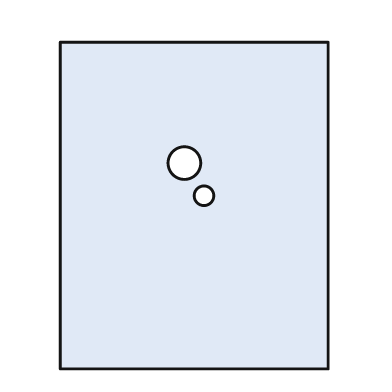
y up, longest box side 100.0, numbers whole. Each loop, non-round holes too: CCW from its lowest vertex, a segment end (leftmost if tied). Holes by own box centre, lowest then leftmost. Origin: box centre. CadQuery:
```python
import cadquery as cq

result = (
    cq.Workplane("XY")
    .moveTo(-41.0, -50.0)
    .lineTo(41.0, -50.0)
    .lineTo(41.0, 50.0)
    .lineTo(-41.0, 50.0)
    .close()
    .moveTo(3.0, 3.0)
    .circle(3.0)
    .moveTo(-3.0, 13.0)
    .circle(5.0)
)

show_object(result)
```